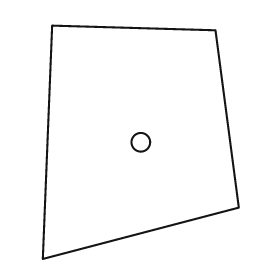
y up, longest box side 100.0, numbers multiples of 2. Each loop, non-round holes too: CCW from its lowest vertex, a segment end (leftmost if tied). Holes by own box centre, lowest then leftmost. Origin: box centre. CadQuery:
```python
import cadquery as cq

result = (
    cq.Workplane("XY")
    .moveTo(-42.0, -50.0)
    .lineTo(42.0, -28.0)
    .lineTo(32.0, 48.0)
    .lineTo(-38.0, 50.0)
    .close()
    .moveTo(0.0, 0.0)
    .circle(4.0)
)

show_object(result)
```